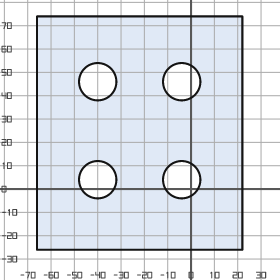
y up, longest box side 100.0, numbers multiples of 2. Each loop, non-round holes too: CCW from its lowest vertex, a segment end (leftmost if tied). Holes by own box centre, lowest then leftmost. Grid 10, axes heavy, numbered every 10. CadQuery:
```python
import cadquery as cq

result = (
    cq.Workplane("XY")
    .moveTo(-66.0, -26.0)
    .lineTo(22.0, -26.0)
    .lineTo(22.0, 74.0)
    .lineTo(-66.0, 74.0)
    .close()
    .moveTo(-40.0, 4.0)
    .circle(8.0)
    .moveTo(-4.0, 4.0)
    .circle(8.0)
    .moveTo(-40.0, 46.0)
    .circle(8.0)
    .moveTo(-4.0, 46.0)
    .circle(8.0)
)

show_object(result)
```